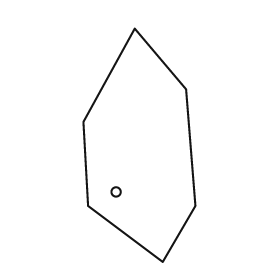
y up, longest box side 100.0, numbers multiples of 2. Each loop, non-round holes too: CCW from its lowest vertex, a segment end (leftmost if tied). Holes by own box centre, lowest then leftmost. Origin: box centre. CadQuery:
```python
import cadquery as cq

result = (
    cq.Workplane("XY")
    .moveTo(10.0, -50.0)
    .lineTo(24.0, -26.0)
    .lineTo(20.0, 24.0)
    .lineTo(-2.0, 50.0)
    .lineTo(-24.0, 10.0)
    .lineTo(-22.0, -26.0)
    .close()
    .moveTo(-10.0, -20.0)
    .circle(2.0)
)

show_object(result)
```